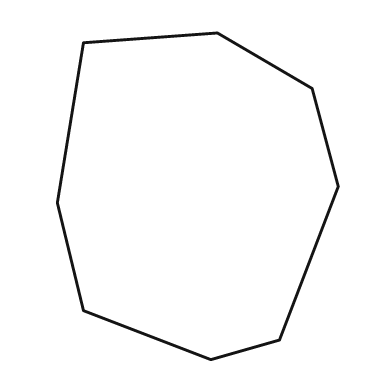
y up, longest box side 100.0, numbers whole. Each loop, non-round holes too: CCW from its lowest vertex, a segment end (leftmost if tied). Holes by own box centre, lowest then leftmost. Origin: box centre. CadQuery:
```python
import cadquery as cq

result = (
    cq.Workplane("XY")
    .moveTo(4.0, -50.0)
    .lineTo(25.0, -44.0)
    .lineTo(43.0, 3.0)
    .lineTo(35.0, 33.0)
    .lineTo(6.0, 50.0)
    .lineTo(-35.0, 47.0)
    .lineTo(-43.0, -2.0)
    .lineTo(-35.0, -35.0)
    .close()
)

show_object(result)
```